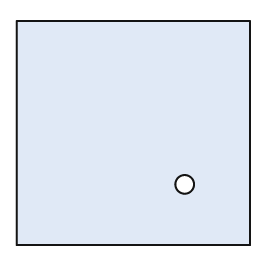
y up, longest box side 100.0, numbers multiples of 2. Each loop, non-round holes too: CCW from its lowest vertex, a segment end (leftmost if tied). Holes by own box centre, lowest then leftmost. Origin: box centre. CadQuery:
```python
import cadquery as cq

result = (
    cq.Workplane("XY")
    .moveTo(-50.0, -48.0)
    .lineTo(50.0, -48.0)
    .lineTo(50.0, 48.0)
    .lineTo(-50.0, 48.0)
    .close()
    .moveTo(22.0, -22.0)
    .circle(4.0)
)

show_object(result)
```